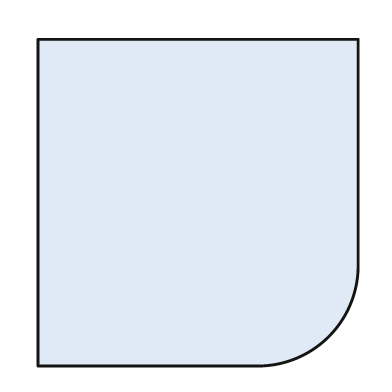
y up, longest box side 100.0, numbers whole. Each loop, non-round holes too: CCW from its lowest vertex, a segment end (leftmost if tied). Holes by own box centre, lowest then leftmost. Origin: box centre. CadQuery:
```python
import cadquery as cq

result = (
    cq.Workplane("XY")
    .moveTo(-49.0, -50.0)
    .lineTo(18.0, -50.0)
    .threePointArc((40.0, -41.0), (49.0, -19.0))
    .lineTo(49.0, 50.0)
    .lineTo(-49.0, 50.0)
    .close()
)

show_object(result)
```